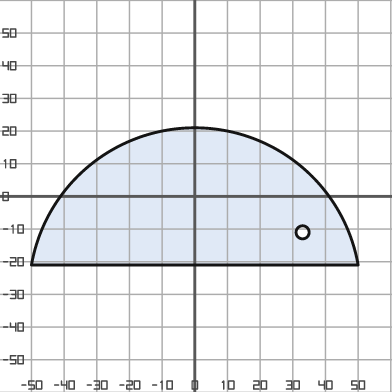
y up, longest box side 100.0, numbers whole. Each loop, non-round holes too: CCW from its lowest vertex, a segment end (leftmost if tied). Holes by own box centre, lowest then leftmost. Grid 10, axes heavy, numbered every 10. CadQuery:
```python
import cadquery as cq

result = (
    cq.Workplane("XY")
    .moveTo(-50.0, -21.0)
    .lineTo(50.0, -21.0)
    .threePointArc((0.0, 21.0), (-50.0, -21.0))
    .close()
    .moveTo(33.0, -11.0)
    .circle(2.0)
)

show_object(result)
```